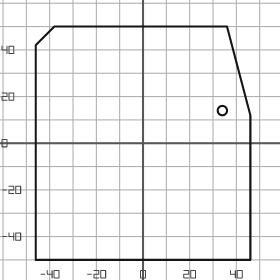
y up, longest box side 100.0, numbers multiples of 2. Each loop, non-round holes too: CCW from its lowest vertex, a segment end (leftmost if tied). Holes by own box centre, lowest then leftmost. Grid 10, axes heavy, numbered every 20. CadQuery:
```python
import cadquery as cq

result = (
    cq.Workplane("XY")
    .moveTo(-46.0, -50.0)
    .lineTo(46.0, -50.0)
    .lineTo(46.0, 12.0)
    .lineTo(36.0, 50.0)
    .lineTo(-38.0, 50.0)
    .lineTo(-46.0, 42.0)
    .close()
    .moveTo(34.0, 14.0)
    .circle(2.0)
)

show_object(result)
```